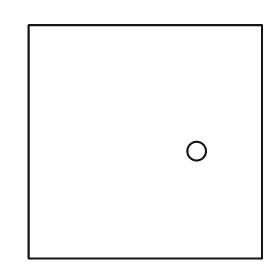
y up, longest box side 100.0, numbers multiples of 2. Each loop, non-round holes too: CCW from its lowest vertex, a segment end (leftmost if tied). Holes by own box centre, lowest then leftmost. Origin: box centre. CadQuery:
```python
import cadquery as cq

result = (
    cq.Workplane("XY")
    .moveTo(-50.0, -50.0)
    .lineTo(50.0, -50.0)
    .lineTo(50.0, 50.0)
    .lineTo(-50.0, 50.0)
    .close()
    .moveTo(22.0, -4.0)
    .circle(4.0)
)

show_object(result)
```